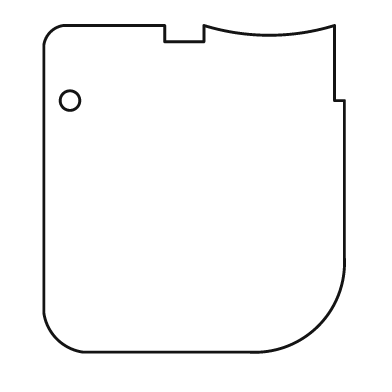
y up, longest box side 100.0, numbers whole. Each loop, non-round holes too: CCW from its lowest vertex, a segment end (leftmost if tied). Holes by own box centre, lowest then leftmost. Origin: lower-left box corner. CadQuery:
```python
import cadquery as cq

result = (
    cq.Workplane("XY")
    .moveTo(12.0, 0.0)
    .lineTo(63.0, 0.0)
    .threePointArc((84.0, 8.0), (92.0, 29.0))
    .lineTo(92.0, 77.0)
    .lineTo(89.0, 77.0)
    .lineTo(89.0, 100.0)
    .threePointArc((69.0, 97.0), (49.0, 100.0))
    .lineTo(49.0, 95.0)
    .lineTo(37.0, 95.0)
    .lineTo(37.0, 100.0)
    .lineTo(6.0, 100.0)
    .threePointArc((2.0, 98.0), (0.0, 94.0))
    .lineTo(0.0, 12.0)
    .threePointArc((4.0, 4.0), (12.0, 0.0))
    .close()
    .moveTo(8.0, 77.0)
    .circle(3.0)
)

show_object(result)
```